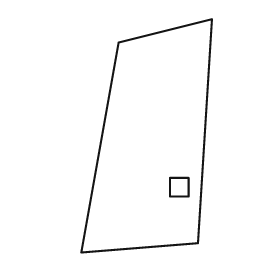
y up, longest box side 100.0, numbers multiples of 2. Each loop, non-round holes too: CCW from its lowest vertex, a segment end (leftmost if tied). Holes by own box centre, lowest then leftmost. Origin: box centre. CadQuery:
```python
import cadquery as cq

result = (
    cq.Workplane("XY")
    .moveTo(-28.0, -50.0)
    .lineTo(22.0, -46.0)
    .lineTo(28.0, 50.0)
    .lineTo(-12.0, 40.0)
    .close()
    .moveTo(10.0, -26.0)
    .lineTo(18.0, -26.0)
    .lineTo(18.0, -18.0)
    .lineTo(10.0, -18.0)
    .close()
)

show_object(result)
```